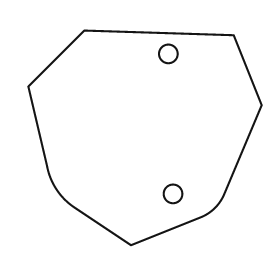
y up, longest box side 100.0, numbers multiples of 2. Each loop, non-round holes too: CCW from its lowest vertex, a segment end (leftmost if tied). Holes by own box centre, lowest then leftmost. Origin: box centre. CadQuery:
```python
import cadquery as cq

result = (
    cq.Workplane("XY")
    .moveTo(-6.0, -46.0)
    .lineTo(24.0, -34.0)
    .threePointArc((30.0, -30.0), (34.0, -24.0))
    .lineTo(50.0, 14.0)
    .lineTo(38.0, 44.0)
    .lineTo(-26.0, 46.0)
    .lineTo(-50.0, 22.0)
    .lineTo(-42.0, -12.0)
    .threePointArc((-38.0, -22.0), (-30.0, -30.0))
    .close()
    .moveTo(12.0, -24.0)
    .circle(4.0)
    .moveTo(10.0, 36.0)
    .circle(4.0)
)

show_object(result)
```